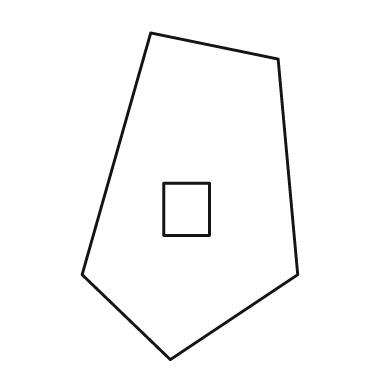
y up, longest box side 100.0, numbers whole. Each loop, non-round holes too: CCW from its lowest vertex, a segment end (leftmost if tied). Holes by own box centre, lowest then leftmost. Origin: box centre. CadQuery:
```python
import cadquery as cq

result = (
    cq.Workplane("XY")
    .moveTo(-6.0, -50.0)
    .lineTo(33.0, -24.0)
    .lineTo(27.0, 42.0)
    .lineTo(-12.0, 50.0)
    .lineTo(-33.0, -24.0)
    .close()
    .moveTo(-8.0, -12.0)
    .lineTo(6.0, -12.0)
    .lineTo(6.0, 4.0)
    .lineTo(-8.0, 4.0)
    .close()
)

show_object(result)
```